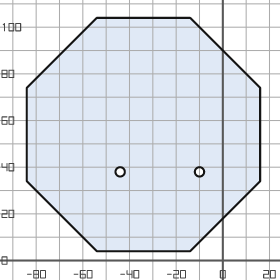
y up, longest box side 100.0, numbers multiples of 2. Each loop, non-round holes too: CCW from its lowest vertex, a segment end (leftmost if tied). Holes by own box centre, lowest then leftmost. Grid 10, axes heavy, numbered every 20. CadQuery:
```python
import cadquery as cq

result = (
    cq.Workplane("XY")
    .moveTo(-54.0, 4.0)
    .lineTo(-14.0, 4.0)
    .lineTo(16.0, 34.0)
    .lineTo(16.0, 74.0)
    .lineTo(-14.0, 104.0)
    .lineTo(-54.0, 104.0)
    .lineTo(-84.0, 74.0)
    .lineTo(-84.0, 34.0)
    .close()
    .moveTo(-44.0, 38.0)
    .circle(2.0)
    .moveTo(-10.0, 38.0)
    .circle(2.0)
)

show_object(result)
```